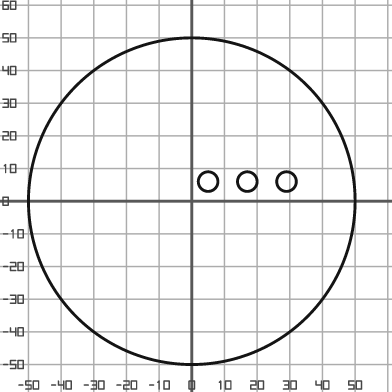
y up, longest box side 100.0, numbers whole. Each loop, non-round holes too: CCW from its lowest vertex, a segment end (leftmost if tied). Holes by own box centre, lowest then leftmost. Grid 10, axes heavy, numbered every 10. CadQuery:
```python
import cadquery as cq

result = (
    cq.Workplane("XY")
    .moveTo(0.0, 0.0)
    .circle(50.0)
    .moveTo(5.0, 6.0)
    .circle(3.0)
    .moveTo(17.0, 6.0)
    .circle(3.0)
    .moveTo(29.0, 6.0)
    .circle(3.0)
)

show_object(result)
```